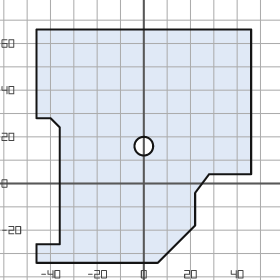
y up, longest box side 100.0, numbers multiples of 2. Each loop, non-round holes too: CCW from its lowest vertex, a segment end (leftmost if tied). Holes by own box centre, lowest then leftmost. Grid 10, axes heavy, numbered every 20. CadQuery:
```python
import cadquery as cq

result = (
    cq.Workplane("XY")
    .moveTo(-46.0, -34.0)
    .lineTo(6.0, -34.0)
    .lineTo(22.0, -18.0)
    .lineTo(22.0, -4.0)
    .lineTo(28.0, 4.0)
    .lineTo(46.0, 4.0)
    .lineTo(46.0, 66.0)
    .lineTo(-46.0, 66.0)
    .lineTo(-46.0, 28.0)
    .lineTo(-40.0, 28.0)
    .lineTo(-36.0, 24.0)
    .lineTo(-36.0, -26.0)
    .lineTo(-46.0, -26.0)
    .close()
    .moveTo(0.0, 16.0)
    .circle(4.0)
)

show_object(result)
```